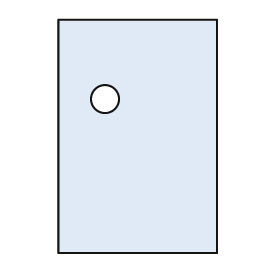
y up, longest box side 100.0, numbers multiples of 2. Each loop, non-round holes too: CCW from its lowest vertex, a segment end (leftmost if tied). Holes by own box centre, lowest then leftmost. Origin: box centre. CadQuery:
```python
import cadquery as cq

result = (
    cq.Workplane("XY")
    .moveTo(-34.0, -50.0)
    .lineTo(34.0, -50.0)
    .lineTo(34.0, 50.0)
    .lineTo(-34.0, 50.0)
    .close()
    .moveTo(-14.0, 16.0)
    .circle(6.0)
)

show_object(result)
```